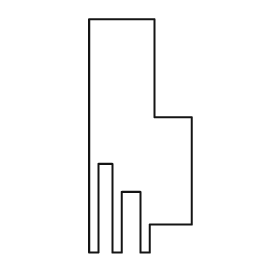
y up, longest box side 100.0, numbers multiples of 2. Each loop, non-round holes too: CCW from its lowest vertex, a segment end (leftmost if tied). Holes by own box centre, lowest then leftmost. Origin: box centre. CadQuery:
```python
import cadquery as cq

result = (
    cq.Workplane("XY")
    .moveTo(-22.0, -50.0)
    .lineTo(-18.0, -50.0)
    .lineTo(-18.0, -12.0)
    .lineTo(-12.0, -12.0)
    .lineTo(-12.0, -50.0)
    .lineTo(-8.0, -50.0)
    .lineTo(-8.0, -24.0)
    .lineTo(0.0, -24.0)
    .lineTo(0.0, -50.0)
    .lineTo(4.0, -50.0)
    .lineTo(4.0, -38.0)
    .lineTo(22.0, -38.0)
    .lineTo(22.0, 8.0)
    .lineTo(6.0, 8.0)
    .lineTo(6.0, 50.0)
    .lineTo(-22.0, 50.0)
    .close()
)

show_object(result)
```